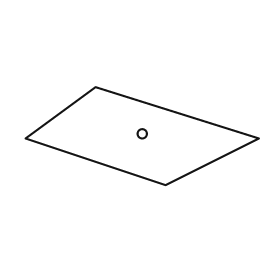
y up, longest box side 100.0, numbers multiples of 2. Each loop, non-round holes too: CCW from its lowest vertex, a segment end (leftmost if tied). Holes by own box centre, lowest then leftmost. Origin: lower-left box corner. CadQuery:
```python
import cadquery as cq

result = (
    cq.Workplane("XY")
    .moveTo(60.0, 0.0)
    .lineTo(100.0, 20.0)
    .lineTo(30.0, 42.0)
    .lineTo(0.0, 20.0)
    .close()
    .moveTo(50.0, 22.0)
    .circle(2.0)
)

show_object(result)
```